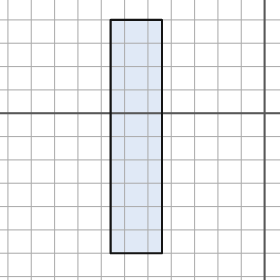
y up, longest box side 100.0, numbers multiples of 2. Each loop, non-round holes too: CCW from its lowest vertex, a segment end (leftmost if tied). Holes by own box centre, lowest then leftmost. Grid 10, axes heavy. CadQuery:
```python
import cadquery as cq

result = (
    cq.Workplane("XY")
    .moveTo(-66.0, -60.0)
    .lineTo(-44.0, -60.0)
    .lineTo(-44.0, 40.0)
    .lineTo(-66.0, 40.0)
    .close()
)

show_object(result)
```